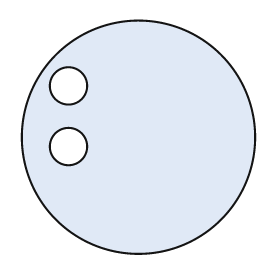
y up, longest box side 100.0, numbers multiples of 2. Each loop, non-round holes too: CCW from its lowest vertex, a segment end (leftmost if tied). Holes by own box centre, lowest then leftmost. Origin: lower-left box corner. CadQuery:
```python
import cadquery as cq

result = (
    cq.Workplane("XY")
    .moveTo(50.0, 50.0)
    .circle(50.0)
    .moveTo(20.0, 46.0)
    .circle(8.0)
    .moveTo(20.0, 72.0)
    .circle(8.0)
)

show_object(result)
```